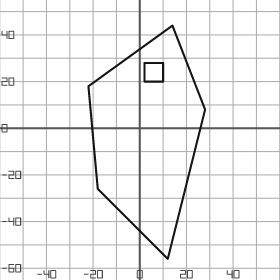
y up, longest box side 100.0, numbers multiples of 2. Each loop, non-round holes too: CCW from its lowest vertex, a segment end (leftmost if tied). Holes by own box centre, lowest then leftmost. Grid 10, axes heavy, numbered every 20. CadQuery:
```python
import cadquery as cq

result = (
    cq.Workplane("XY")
    .moveTo(12.0, -56.0)
    .lineTo(28.0, 8.0)
    .lineTo(14.0, 44.0)
    .lineTo(-22.0, 18.0)
    .lineTo(-18.0, -26.0)
    .close()
    .moveTo(2.0, 20.0)
    .lineTo(10.0, 20.0)
    .lineTo(10.0, 28.0)
    .lineTo(2.0, 28.0)
    .close()
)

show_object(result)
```